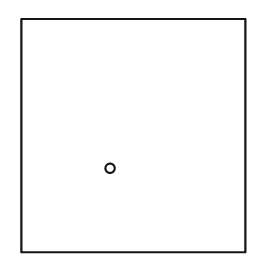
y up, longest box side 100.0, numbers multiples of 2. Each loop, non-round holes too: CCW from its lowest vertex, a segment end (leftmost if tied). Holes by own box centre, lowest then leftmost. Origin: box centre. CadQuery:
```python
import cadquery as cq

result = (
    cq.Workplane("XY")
    .moveTo(-48.0, -50.0)
    .lineTo(48.0, -50.0)
    .lineTo(48.0, 50.0)
    .lineTo(-48.0, 50.0)
    .close()
    .moveTo(-10.0, -14.0)
    .circle(2.0)
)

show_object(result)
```